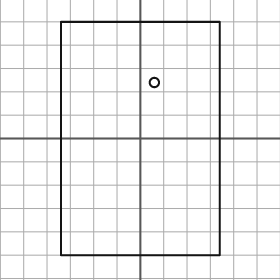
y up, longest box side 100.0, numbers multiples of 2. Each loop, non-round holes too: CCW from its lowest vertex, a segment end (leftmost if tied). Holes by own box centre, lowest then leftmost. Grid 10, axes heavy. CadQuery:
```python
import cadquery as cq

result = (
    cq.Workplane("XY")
    .moveTo(-34.0, -50.0)
    .lineTo(34.0, -50.0)
    .lineTo(34.0, 50.0)
    .lineTo(-34.0, 50.0)
    .close()
    .moveTo(6.0, 24.0)
    .circle(2.0)
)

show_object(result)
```